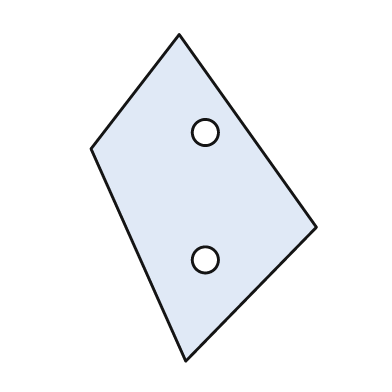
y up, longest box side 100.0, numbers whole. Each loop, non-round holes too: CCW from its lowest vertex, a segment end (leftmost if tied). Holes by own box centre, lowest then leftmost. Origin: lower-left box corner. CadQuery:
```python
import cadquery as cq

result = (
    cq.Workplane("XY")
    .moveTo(29.0, 0.0)
    .lineTo(69.0, 41.0)
    .lineTo(27.0, 100.0)
    .lineTo(0.0, 65.0)
    .close()
    .moveTo(35.0, 31.0)
    .circle(4.0)
    .moveTo(35.0, 70.0)
    .circle(4.0)
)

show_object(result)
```